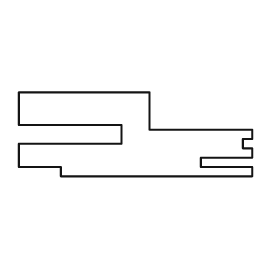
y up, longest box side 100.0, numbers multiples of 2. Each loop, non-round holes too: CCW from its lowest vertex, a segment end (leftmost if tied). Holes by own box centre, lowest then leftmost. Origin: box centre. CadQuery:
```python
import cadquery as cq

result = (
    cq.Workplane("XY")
    .moveTo(-32.0, -18.0)
    .lineTo(50.0, -18.0)
    .lineTo(50.0, -14.0)
    .lineTo(28.0, -14.0)
    .lineTo(28.0, -10.0)
    .lineTo(50.0, -10.0)
    .lineTo(50.0, -6.0)
    .lineTo(46.0, -6.0)
    .lineTo(46.0, -2.0)
    .lineTo(50.0, -2.0)
    .lineTo(50.0, 2.0)
    .lineTo(6.0, 2.0)
    .lineTo(6.0, 18.0)
    .lineTo(-50.0, 18.0)
    .lineTo(-50.0, 4.0)
    .lineTo(-6.0, 4.0)
    .lineTo(-6.0, -4.0)
    .lineTo(-50.0, -4.0)
    .lineTo(-50.0, -14.0)
    .lineTo(-32.0, -14.0)
    .close()
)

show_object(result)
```